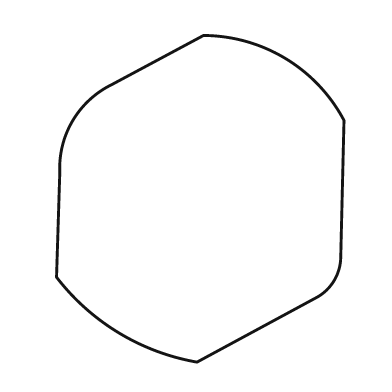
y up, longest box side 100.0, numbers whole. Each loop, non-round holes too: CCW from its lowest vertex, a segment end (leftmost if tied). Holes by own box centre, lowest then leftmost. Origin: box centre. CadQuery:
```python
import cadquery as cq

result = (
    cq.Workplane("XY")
    .moveTo(-1.0, -50.0)
    .lineTo(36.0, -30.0)
    .threePointArc((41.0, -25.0), (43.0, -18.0))
    .lineTo(44.0, 24.0)
    .threePointArc((26.0, 43.0), (1.0, 50.0))
    .lineTo(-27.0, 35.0)
    .threePointArc((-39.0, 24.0), (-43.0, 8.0))
    .lineTo(-44.0, -24.0)
    .threePointArc((-25.0, -41.0), (-1.0, -50.0))
    .close()
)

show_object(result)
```